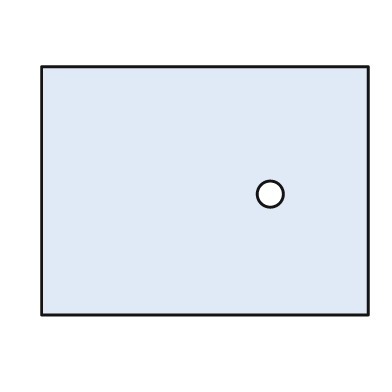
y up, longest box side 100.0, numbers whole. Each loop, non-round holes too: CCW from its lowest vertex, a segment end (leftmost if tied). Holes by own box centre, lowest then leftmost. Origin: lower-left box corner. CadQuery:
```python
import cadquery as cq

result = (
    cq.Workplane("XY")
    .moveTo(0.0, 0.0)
    .lineTo(100.0, 0.0)
    .lineTo(100.0, 76.0)
    .lineTo(0.0, 76.0)
    .close()
    .moveTo(70.0, 37.0)
    .circle(4.0)
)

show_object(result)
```